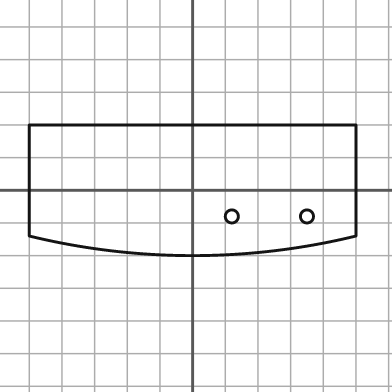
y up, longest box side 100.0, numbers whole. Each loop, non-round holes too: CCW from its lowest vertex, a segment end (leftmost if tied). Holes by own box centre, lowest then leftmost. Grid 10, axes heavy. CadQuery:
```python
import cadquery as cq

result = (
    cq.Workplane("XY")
    .moveTo(-50.0, -14.0)
    .threePointArc((0.0, -20.0), (50.0, -14.0))
    .lineTo(50.0, 20.0)
    .lineTo(-50.0, 20.0)
    .close()
    .moveTo(12.0, -8.0)
    .circle(2.0)
    .moveTo(35.0, -8.0)
    .circle(2.0)
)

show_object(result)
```